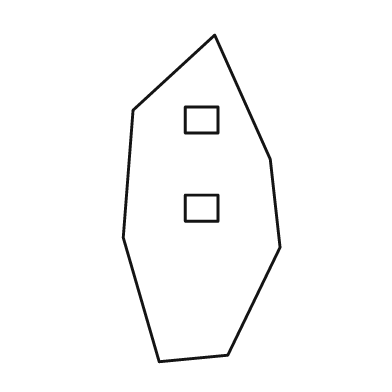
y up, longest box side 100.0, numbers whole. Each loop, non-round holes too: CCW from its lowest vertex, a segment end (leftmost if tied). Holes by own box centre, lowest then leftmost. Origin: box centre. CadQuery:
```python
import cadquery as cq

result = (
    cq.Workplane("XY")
    .moveTo(-13.0, -50.0)
    .lineTo(8.0, -48.0)
    .lineTo(24.0, -15.0)
    .lineTo(21.0, 12.0)
    .lineTo(4.0, 50.0)
    .lineTo(-21.0, 27.0)
    .lineTo(-24.0, -12.0)
    .close()
    .moveTo(-5.0, -7.0)
    .lineTo(5.0, -7.0)
    .lineTo(5.0, 1.0)
    .lineTo(-5.0, 1.0)
    .close()
    .moveTo(-5.0, 20.0)
    .lineTo(5.0, 20.0)
    .lineTo(5.0, 28.0)
    .lineTo(-5.0, 28.0)
    .close()
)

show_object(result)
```